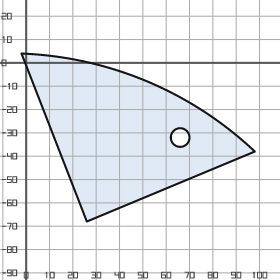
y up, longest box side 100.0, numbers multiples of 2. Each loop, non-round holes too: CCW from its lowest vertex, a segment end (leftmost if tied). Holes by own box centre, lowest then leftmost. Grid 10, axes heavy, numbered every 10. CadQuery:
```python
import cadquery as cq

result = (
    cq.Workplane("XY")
    .moveTo(26.0, -68.0)
    .lineTo(98.0, -38.0)
    .threePointArc((52.0, -8.0), (-2.0, 4.0))
    .close()
    .moveTo(66.0, -32.0)
    .circle(4.0)
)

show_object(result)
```